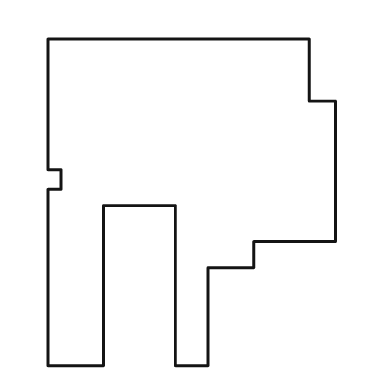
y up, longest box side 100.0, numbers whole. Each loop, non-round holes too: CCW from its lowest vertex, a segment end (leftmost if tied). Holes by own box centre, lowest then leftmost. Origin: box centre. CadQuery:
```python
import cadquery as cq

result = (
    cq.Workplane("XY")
    .moveTo(-44.0, -50.0)
    .lineTo(-27.0, -50.0)
    .lineTo(-27.0, -1.0)
    .lineTo(-5.0, -1.0)
    .lineTo(-5.0, -50.0)
    .lineTo(5.0, -50.0)
    .lineTo(5.0, -20.0)
    .lineTo(19.0, -20.0)
    .lineTo(19.0, -12.0)
    .lineTo(44.0, -12.0)
    .lineTo(44.0, 31.0)
    .lineTo(36.0, 31.0)
    .lineTo(36.0, 50.0)
    .lineTo(-44.0, 50.0)
    .lineTo(-44.0, 10.0)
    .lineTo(-40.0, 10.0)
    .lineTo(-40.0, 4.0)
    .lineTo(-44.0, 4.0)
    .close()
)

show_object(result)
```